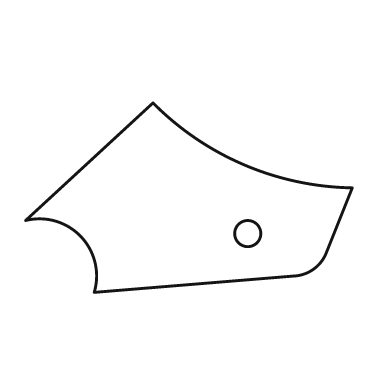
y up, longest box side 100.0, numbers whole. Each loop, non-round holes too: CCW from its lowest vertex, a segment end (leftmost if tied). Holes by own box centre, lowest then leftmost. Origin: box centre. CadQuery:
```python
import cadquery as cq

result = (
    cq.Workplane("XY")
    .moveTo(-29.0, -29.0)
    .lineTo(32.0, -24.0)
    .threePointArc((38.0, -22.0), (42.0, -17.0))
    .lineTo(50.0, 3.0)
    .threePointArc((17.0, 10.0), (-11.0, 29.0))
    .lineTo(-50.0, -7.0)
    .threePointArc((-33.0, -12.0), (-29.0, -29.0))
    .close()
    .moveTo(18.0, -11.0)
    .circle(4.0)
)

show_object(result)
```